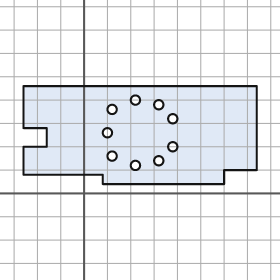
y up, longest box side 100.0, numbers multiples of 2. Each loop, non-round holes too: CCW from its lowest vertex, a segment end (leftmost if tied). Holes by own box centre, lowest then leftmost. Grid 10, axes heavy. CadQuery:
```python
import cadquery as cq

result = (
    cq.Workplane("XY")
    .moveTo(8.0, 4.0)
    .lineTo(60.0, 4.0)
    .lineTo(60.0, 10.0)
    .lineTo(74.0, 10.0)
    .lineTo(74.0, 46.0)
    .lineTo(-26.0, 46.0)
    .lineTo(-26.0, 28.0)
    .lineTo(-16.0, 28.0)
    .lineTo(-16.0, 20.0)
    .lineTo(-26.0, 20.0)
    .lineTo(-26.0, 8.0)
    .lineTo(8.0, 8.0)
    .close()
    .moveTo(22.0, 12.0)
    .circle(2.0)
    .moveTo(32.0, 14.0)
    .circle(2.0)
    .moveTo(12.0, 16.0)
    .circle(2.0)
    .moveTo(38.0, 20.0)
    .circle(2.0)
    .moveTo(10.0, 26.0)
    .circle(2.0)
    .moveTo(38.0, 32.0)
    .circle(2.0)
    .moveTo(12.0, 36.0)
    .circle(2.0)
    .moveTo(32.0, 38.0)
    .circle(2.0)
    .moveTo(22.0, 40.0)
    .circle(2.0)
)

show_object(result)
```